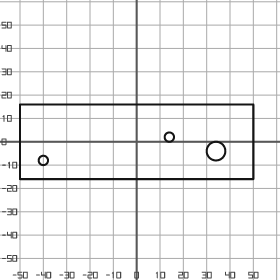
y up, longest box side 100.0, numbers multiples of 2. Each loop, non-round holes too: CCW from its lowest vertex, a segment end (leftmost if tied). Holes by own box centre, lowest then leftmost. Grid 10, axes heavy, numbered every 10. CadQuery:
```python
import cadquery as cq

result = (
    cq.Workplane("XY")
    .moveTo(-50.0, -16.0)
    .lineTo(50.0, -16.0)
    .lineTo(50.0, 16.0)
    .lineTo(-50.0, 16.0)
    .close()
    .moveTo(-40.0, -8.0)
    .circle(2.0)
    .moveTo(34.0, -4.0)
    .circle(4.0)
    .moveTo(14.0, 2.0)
    .circle(2.0)
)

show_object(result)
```